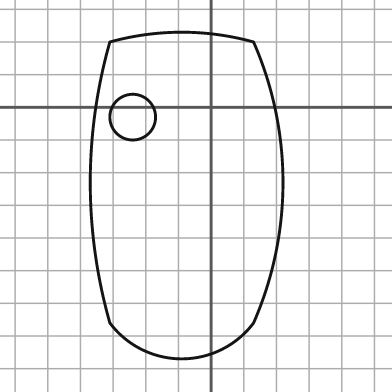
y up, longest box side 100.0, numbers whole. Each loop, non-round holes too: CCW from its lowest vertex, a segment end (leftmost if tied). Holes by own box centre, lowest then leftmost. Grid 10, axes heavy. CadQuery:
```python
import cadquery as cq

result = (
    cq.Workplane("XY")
    .moveTo(-31.0, -66.0)
    .threePointArc((-9.0, -77.0), (13.0, -66.0))
    .threePointArc((22.0, -23.0), (13.0, 20.0))
    .threePointArc((-9.0, 23.0), (-31.0, 20.0))
    .threePointArc((-37.0, -23.0), (-31.0, -66.0))
    .close()
    .moveTo(-24.0, -3.0)
    .circle(7.0)
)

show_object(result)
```